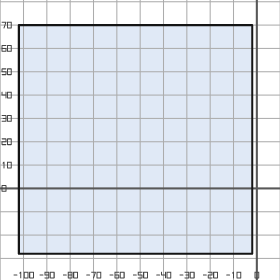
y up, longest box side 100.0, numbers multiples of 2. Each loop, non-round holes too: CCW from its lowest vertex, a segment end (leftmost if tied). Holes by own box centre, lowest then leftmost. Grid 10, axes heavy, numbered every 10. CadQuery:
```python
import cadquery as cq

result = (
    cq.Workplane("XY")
    .moveTo(-102.0, -28.0)
    .lineTo(-2.0, -28.0)
    .lineTo(-2.0, 70.0)
    .lineTo(-102.0, 70.0)
    .close()
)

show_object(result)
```